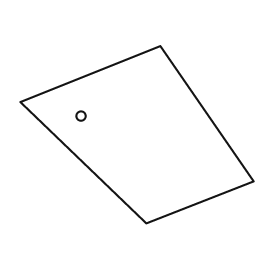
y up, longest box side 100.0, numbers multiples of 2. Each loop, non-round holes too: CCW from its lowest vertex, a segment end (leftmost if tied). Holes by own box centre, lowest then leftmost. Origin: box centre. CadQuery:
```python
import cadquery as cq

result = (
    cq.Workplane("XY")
    .moveTo(4.0, -38.0)
    .lineTo(50.0, -20.0)
    .lineTo(10.0, 38.0)
    .lineTo(-50.0, 14.0)
    .close()
    .moveTo(-24.0, 8.0)
    .circle(2.0)
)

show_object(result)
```